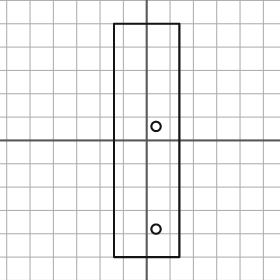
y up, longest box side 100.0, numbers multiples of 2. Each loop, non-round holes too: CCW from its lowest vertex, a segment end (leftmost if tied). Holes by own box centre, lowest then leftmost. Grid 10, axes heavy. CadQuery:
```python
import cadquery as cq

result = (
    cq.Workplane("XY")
    .moveTo(-14.0, -50.0)
    .lineTo(14.0, -50.0)
    .lineTo(14.0, 50.0)
    .lineTo(-14.0, 50.0)
    .close()
    .moveTo(4.0, -38.0)
    .circle(2.0)
    .moveTo(4.0, 6.0)
    .circle(2.0)
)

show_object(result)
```